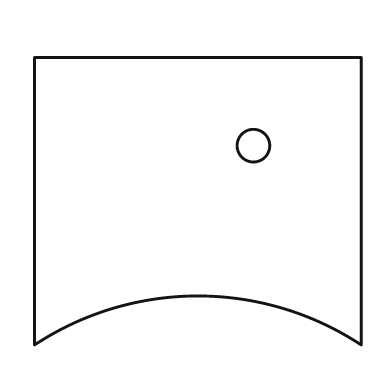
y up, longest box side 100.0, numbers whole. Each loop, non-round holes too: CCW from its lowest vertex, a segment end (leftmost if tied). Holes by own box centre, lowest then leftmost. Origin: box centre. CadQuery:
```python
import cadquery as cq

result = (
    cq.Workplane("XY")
    .moveTo(-50.0, -44.0)
    .threePointArc((0.0, -29.0), (50.0, -44.0))
    .lineTo(50.0, 44.0)
    .lineTo(-50.0, 44.0)
    .close()
    .moveTo(17.0, 17.0)
    .circle(5.0)
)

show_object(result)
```